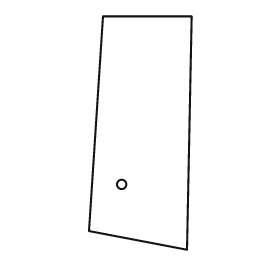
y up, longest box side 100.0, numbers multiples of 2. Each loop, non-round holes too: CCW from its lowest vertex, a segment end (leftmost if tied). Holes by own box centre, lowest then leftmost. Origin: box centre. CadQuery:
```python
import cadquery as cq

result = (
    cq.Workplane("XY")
    .moveTo(20.0, -50.0)
    .lineTo(22.0, 50.0)
    .lineTo(-16.0, 50.0)
    .lineTo(-22.0, -42.0)
    .close()
    .moveTo(-8.0, -22.0)
    .circle(2.0)
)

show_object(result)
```